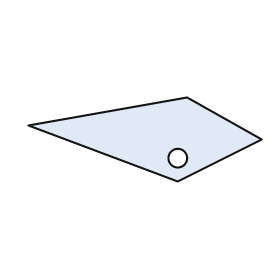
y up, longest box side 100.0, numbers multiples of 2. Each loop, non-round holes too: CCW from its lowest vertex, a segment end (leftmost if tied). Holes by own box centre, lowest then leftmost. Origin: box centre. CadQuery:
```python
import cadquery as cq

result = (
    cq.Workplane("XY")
    .moveTo(14.0, -18.0)
    .lineTo(50.0, 0.0)
    .lineTo(18.0, 18.0)
    .lineTo(-50.0, 6.0)
    .close()
    .moveTo(14.0, -8.0)
    .circle(4.0)
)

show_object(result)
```